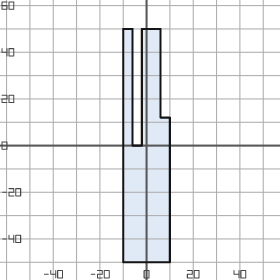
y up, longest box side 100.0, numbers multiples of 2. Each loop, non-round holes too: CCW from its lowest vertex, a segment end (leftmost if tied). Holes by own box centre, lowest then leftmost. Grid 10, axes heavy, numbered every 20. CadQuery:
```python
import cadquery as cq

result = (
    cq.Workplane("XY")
    .moveTo(-10.0, -50.0)
    .lineTo(10.0, -50.0)
    .lineTo(10.0, 12.0)
    .lineTo(6.0, 12.0)
    .lineTo(6.0, 50.0)
    .lineTo(-2.0, 50.0)
    .lineTo(-2.0, 0.0)
    .lineTo(-6.0, 0.0)
    .lineTo(-6.0, 50.0)
    .lineTo(-10.0, 50.0)
    .close()
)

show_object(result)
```